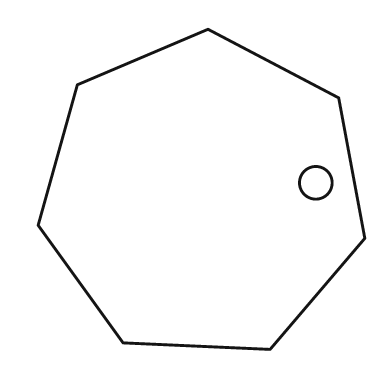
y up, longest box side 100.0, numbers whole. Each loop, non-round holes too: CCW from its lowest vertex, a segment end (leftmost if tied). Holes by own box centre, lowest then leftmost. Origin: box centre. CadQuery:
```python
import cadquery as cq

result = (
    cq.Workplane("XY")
    .moveTo(21.0, -49.0)
    .lineTo(50.0, -15.0)
    .lineTo(42.0, 28.0)
    .lineTo(2.0, 49.0)
    .lineTo(-38.0, 32.0)
    .lineTo(-50.0, -11.0)
    .lineTo(-24.0, -47.0)
    .close()
    .moveTo(35.0, 2.0)
    .circle(5.0)
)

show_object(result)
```